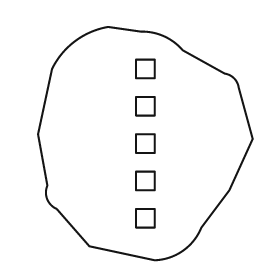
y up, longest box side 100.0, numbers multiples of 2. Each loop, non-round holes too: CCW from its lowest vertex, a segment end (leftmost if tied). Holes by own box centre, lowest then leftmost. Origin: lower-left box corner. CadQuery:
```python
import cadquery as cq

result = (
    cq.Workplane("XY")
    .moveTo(50.0, 0.0)
    .threePointArc((62.0, 4.0), (70.0, 14.0))
    .lineTo(82.0, 30.0)
    .lineTo(92.0, 52.0)
    .lineTo(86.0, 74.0)
    .threePointArc((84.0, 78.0), (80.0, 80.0))
    .lineTo(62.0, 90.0)
    .threePointArc((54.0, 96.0), (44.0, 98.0))
    .lineTo(30.0, 100.0)
    .threePointArc((16.0, 94.0), (6.0, 82.0))
    .lineTo(0.0, 54.0)
    .lineTo(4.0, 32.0)
    .threePointArc((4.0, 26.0), (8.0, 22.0))
    .lineTo(22.0, 6.0)
    .close()
    .moveTo(42.0, 14.0)
    .lineTo(50.0, 14.0)
    .lineTo(50.0, 22.0)
    .lineTo(42.0, 22.0)
    .close()
    .moveTo(42.0, 30.0)
    .lineTo(50.0, 30.0)
    .lineTo(50.0, 38.0)
    .lineTo(42.0, 38.0)
    .close()
    .moveTo(42.0, 46.0)
    .lineTo(50.0, 46.0)
    .lineTo(50.0, 54.0)
    .lineTo(42.0, 54.0)
    .close()
    .moveTo(42.0, 62.0)
    .lineTo(50.0, 62.0)
    .lineTo(50.0, 70.0)
    .lineTo(42.0, 70.0)
    .close()
    .moveTo(42.0, 78.0)
    .lineTo(50.0, 78.0)
    .lineTo(50.0, 86.0)
    .lineTo(42.0, 86.0)
    .close()
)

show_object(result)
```